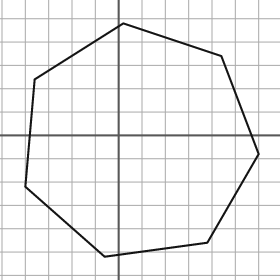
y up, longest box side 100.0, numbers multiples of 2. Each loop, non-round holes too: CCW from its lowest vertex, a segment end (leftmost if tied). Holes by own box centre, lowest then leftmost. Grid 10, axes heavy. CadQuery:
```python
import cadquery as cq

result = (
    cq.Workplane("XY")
    .moveTo(-6.0, -52.0)
    .lineTo(38.0, -46.0)
    .lineTo(60.0, -8.0)
    .lineTo(44.0, 34.0)
    .lineTo(2.0, 48.0)
    .lineTo(-36.0, 24.0)
    .lineTo(-40.0, -22.0)
    .close()
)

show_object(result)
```